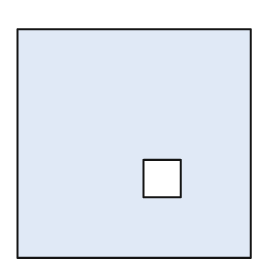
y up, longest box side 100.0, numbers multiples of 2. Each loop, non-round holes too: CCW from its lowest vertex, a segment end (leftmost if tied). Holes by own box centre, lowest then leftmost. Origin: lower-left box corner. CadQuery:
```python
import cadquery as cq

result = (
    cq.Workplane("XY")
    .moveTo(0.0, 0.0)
    .lineTo(100.0, 0.0)
    .lineTo(100.0, 98.0)
    .lineTo(0.0, 98.0)
    .close()
    .moveTo(54.0, 26.0)
    .lineTo(70.0, 26.0)
    .lineTo(70.0, 42.0)
    .lineTo(54.0, 42.0)
    .close()
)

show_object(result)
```